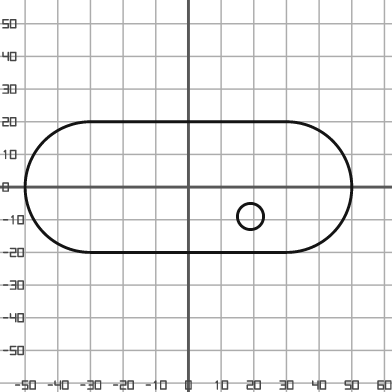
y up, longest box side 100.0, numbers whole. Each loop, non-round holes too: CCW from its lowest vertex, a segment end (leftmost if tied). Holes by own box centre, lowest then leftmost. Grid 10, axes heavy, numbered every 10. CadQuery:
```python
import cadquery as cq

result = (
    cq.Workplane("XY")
    .moveTo(-30.0, -20.0)
    .lineTo(30.0, -20.0)
    .threePointArc((50.0, 0.0), (30.0, 20.0))
    .lineTo(-30.0, 20.0)
    .threePointArc((-50.0, 0.0), (-30.0, -20.0))
    .close()
    .moveTo(19.0, -9.0)
    .circle(4.0)
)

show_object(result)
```